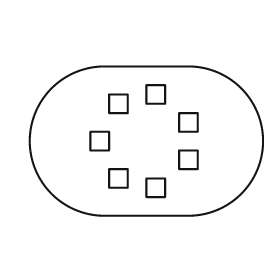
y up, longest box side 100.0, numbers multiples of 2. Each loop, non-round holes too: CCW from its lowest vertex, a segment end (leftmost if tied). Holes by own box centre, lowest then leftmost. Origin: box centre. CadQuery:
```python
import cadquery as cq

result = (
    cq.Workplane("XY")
    .moveTo(-18.0, -32.0)
    .lineTo(18.0, -32.0)
    .threePointArc((50.0, 0.0), (18.0, 32.0))
    .lineTo(-18.0, 32.0)
    .threePointArc((-50.0, 0.0), (-18.0, -32.0))
    .close()
    .moveTo(0.0, -24.0)
    .lineTo(8.0, -24.0)
    .lineTo(8.0, -16.0)
    .lineTo(0.0, -16.0)
    .close()
    .moveTo(-16.0, -20.0)
    .lineTo(-8.0, -20.0)
    .lineTo(-8.0, -12.0)
    .lineTo(-16.0, -12.0)
    .close()
    .moveTo(14.0, -12.0)
    .lineTo(22.0, -12.0)
    .lineTo(22.0, -4.0)
    .lineTo(14.0, -4.0)
    .close()
    .moveTo(-24.0, -4.0)
    .lineTo(-16.0, -4.0)
    .lineTo(-16.0, 4.0)
    .lineTo(-24.0, 4.0)
    .close()
    .moveTo(14.0, 4.0)
    .lineTo(22.0, 4.0)
    .lineTo(22.0, 12.0)
    .lineTo(14.0, 12.0)
    .close()
    .moveTo(-16.0, 12.0)
    .lineTo(-8.0, 12.0)
    .lineTo(-8.0, 20.0)
    .lineTo(-16.0, 20.0)
    .close()
    .moveTo(0.0, 16.0)
    .lineTo(8.0, 16.0)
    .lineTo(8.0, 24.0)
    .lineTo(0.0, 24.0)
    .close()
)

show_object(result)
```